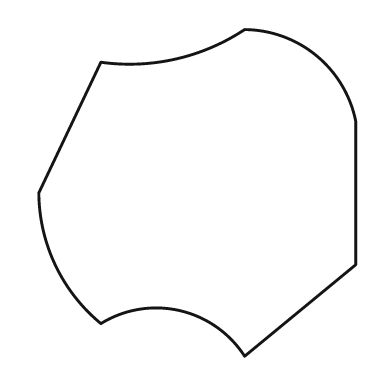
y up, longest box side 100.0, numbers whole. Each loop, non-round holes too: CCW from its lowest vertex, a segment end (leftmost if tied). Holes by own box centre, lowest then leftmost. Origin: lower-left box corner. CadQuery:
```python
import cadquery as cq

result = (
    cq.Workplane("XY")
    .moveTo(63.0, 0.0)
    .lineTo(97.0, 28.0)
    .lineTo(97.0, 72.0)
    .threePointArc((85.0, 92.0), (63.0, 100.0))
    .threePointArc((42.0, 91.0), (19.0, 90.0))
    .lineTo(0.0, 50.0)
    .threePointArc((5.0, 28.0), (19.0, 10.0))
    .threePointArc((43.0, 14.0), (63.0, 0.0))
    .close()
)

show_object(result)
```